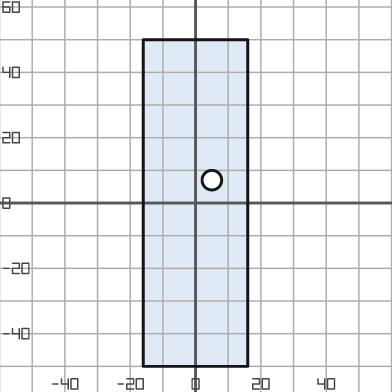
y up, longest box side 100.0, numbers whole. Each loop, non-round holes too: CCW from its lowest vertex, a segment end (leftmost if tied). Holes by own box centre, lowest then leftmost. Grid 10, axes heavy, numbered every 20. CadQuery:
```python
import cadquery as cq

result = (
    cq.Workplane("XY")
    .moveTo(-16.0, -50.0)
    .lineTo(16.0, -50.0)
    .lineTo(16.0, 50.0)
    .lineTo(-16.0, 50.0)
    .close()
    .moveTo(5.0, 7.0)
    .circle(3.0)
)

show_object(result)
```